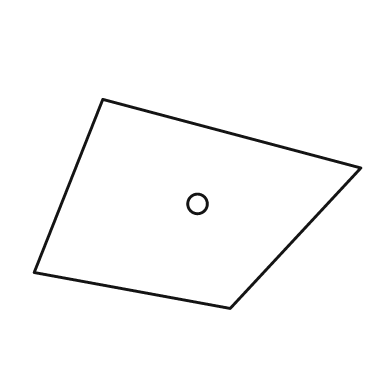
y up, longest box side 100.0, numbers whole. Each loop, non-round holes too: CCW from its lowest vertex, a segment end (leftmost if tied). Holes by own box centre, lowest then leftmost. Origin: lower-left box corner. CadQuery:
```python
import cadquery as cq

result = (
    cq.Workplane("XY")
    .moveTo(60.0, 0.0)
    .lineTo(100.0, 43.0)
    .lineTo(21.0, 64.0)
    .lineTo(0.0, 11.0)
    .close()
    .moveTo(50.0, 32.0)
    .circle(3.0)
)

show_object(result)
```